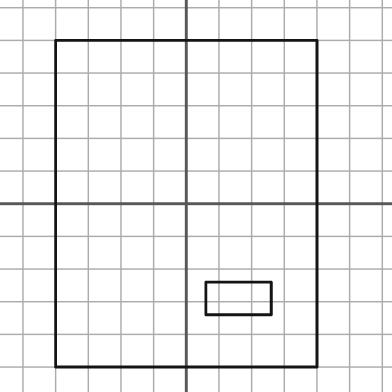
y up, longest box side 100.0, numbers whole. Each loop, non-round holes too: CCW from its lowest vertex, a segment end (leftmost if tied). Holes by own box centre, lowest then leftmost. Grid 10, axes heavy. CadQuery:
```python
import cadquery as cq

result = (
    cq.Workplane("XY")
    .moveTo(-40.0, -50.0)
    .lineTo(40.0, -50.0)
    .lineTo(40.0, 50.0)
    .lineTo(-40.0, 50.0)
    .close()
    .moveTo(6.0, -34.0)
    .lineTo(26.0, -34.0)
    .lineTo(26.0, -24.0)
    .lineTo(6.0, -24.0)
    .close()
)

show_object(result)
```